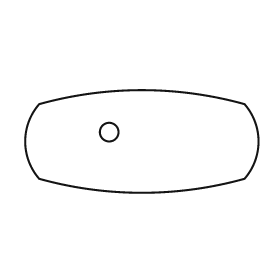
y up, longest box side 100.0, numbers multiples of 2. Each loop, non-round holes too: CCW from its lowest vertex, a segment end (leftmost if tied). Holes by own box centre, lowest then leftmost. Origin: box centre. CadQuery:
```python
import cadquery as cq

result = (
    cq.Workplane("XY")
    .moveTo(-44.0, -16.0)
    .threePointArc((0.0, -22.0), (44.0, -16.0))
    .threePointArc((50.0, 0.0), (44.0, 16.0))
    .threePointArc((0.0, 22.0), (-44.0, 16.0))
    .threePointArc((-50.0, 0.0), (-44.0, -16.0))
    .close()
    .moveTo(-14.0, 4.0)
    .circle(4.0)
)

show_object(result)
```